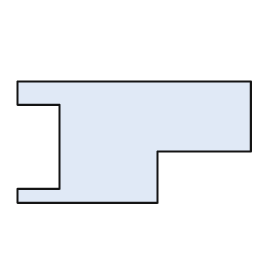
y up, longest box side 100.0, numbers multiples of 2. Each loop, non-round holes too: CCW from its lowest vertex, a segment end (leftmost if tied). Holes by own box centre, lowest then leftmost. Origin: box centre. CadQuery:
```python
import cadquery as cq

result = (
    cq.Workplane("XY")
    .moveTo(-50.0, -26.0)
    .lineTo(10.0, -26.0)
    .lineTo(10.0, -4.0)
    .lineTo(50.0, -4.0)
    .lineTo(50.0, 26.0)
    .lineTo(-50.0, 26.0)
    .lineTo(-50.0, 16.0)
    .lineTo(-32.0, 16.0)
    .lineTo(-32.0, -20.0)
    .lineTo(-50.0, -20.0)
    .close()
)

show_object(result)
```